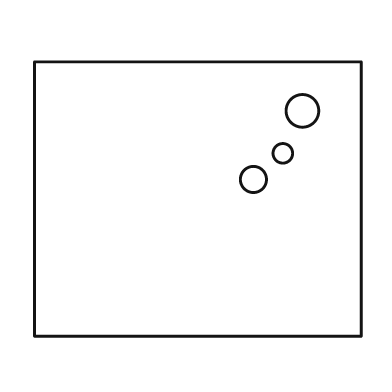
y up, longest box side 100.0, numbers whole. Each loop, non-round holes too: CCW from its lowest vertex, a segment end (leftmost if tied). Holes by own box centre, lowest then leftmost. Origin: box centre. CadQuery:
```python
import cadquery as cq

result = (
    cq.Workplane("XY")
    .moveTo(-50.0, -42.0)
    .lineTo(50.0, -42.0)
    .lineTo(50.0, 42.0)
    .lineTo(-50.0, 42.0)
    .close()
    .moveTo(17.0, 6.0)
    .circle(4.0)
    .moveTo(26.0, 14.0)
    .circle(3.0)
    .moveTo(32.0, 27.0)
    .circle(5.0)
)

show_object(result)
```